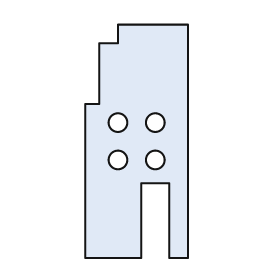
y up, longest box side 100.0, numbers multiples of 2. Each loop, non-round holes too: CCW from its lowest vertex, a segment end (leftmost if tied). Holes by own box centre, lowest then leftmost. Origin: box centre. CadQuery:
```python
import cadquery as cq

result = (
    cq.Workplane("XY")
    .moveTo(-22.0, -50.0)
    .lineTo(2.0, -50.0)
    .lineTo(2.0, -18.0)
    .lineTo(14.0, -18.0)
    .lineTo(14.0, -50.0)
    .lineTo(22.0, -50.0)
    .lineTo(22.0, 50.0)
    .lineTo(-8.0, 50.0)
    .lineTo(-8.0, 42.0)
    .lineTo(-16.0, 42.0)
    .lineTo(-16.0, 16.0)
    .lineTo(-22.0, 16.0)
    .close()
    .moveTo(-8.0, -8.0)
    .circle(4.0)
    .moveTo(8.0, -8.0)
    .circle(4.0)
    .moveTo(-8.0, 8.0)
    .circle(4.0)
    .moveTo(8.0, 8.0)
    .circle(4.0)
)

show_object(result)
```